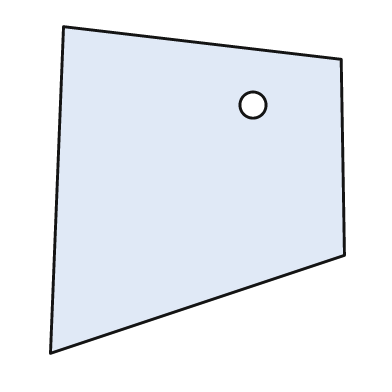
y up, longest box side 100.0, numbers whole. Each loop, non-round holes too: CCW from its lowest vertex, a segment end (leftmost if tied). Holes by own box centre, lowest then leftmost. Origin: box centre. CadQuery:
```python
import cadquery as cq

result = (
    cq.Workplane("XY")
    .moveTo(-45.0, -50.0)
    .lineTo(45.0, -20.0)
    .lineTo(44.0, 40.0)
    .lineTo(-41.0, 50.0)
    .close()
    .moveTo(17.0, 26.0)
    .circle(4.0)
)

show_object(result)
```